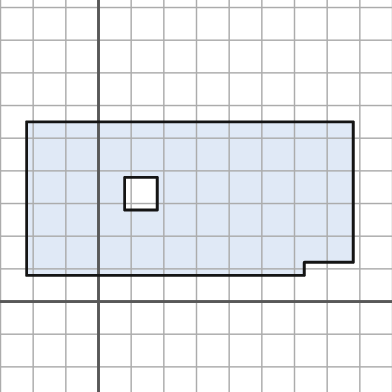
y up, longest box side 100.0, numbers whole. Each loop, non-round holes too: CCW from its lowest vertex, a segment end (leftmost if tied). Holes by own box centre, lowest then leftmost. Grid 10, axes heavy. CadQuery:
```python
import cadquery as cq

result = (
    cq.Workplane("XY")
    .moveTo(-22.0, 8.0)
    .lineTo(63.0, 8.0)
    .lineTo(63.0, 12.0)
    .lineTo(78.0, 12.0)
    .lineTo(78.0, 55.0)
    .lineTo(-22.0, 55.0)
    .close()
    .moveTo(8.0, 28.0)
    .lineTo(18.0, 28.0)
    .lineTo(18.0, 38.0)
    .lineTo(8.0, 38.0)
    .close()
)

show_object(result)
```